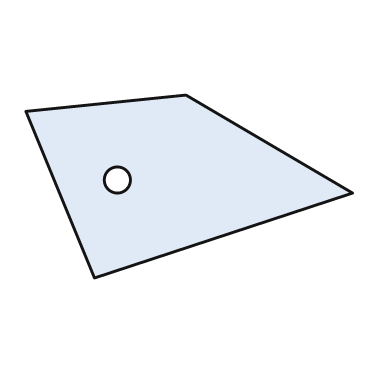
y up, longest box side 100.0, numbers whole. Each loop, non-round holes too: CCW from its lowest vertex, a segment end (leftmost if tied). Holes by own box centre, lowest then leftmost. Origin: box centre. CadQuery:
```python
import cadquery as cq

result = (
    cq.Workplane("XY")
    .moveTo(-29.0, -28.0)
    .lineTo(50.0, -2.0)
    .lineTo(-1.0, 28.0)
    .lineTo(-50.0, 23.0)
    .close()
    .moveTo(-22.0, 2.0)
    .circle(4.0)
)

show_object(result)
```